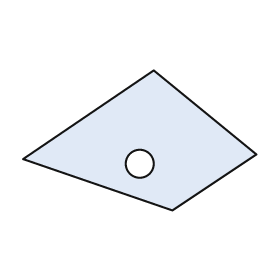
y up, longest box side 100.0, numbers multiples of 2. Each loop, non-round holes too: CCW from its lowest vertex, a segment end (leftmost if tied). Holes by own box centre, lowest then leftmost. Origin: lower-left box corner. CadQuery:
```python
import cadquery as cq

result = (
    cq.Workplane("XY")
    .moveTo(64.0, 0.0)
    .lineTo(100.0, 24.0)
    .lineTo(56.0, 60.0)
    .lineTo(0.0, 22.0)
    .close()
    .moveTo(50.0, 20.0)
    .circle(6.0)
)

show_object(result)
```